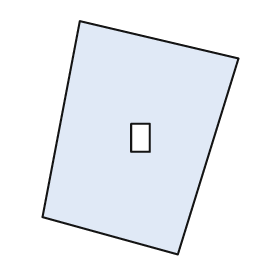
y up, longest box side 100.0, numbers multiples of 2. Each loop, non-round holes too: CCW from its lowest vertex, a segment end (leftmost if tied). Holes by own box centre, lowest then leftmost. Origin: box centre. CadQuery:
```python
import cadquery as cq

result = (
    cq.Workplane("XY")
    .moveTo(16.0, -50.0)
    .lineTo(42.0, 34.0)
    .lineTo(-26.0, 50.0)
    .lineTo(-42.0, -34.0)
    .close()
    .moveTo(-4.0, -6.0)
    .lineTo(4.0, -6.0)
    .lineTo(4.0, 6.0)
    .lineTo(-4.0, 6.0)
    .close()
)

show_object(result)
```